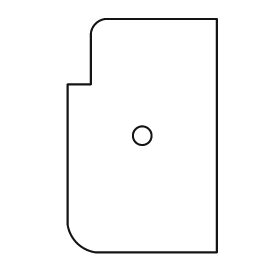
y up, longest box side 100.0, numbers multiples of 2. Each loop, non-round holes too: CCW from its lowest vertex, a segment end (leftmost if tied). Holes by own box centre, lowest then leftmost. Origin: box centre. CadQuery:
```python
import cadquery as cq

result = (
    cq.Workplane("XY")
    .moveTo(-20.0, -50.0)
    .lineTo(32.0, -50.0)
    .lineTo(32.0, 50.0)
    .lineTo(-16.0, 50.0)
    .threePointArc((-20.0, 48.0), (-22.0, 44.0))
    .lineTo(-22.0, 22.0)
    .lineTo(-32.0, 22.0)
    .lineTo(-32.0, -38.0)
    .threePointArc((-28.0, -46.0), (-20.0, -50.0))
    .close()
    .moveTo(0.0, 0.0)
    .circle(4.0)
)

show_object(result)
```